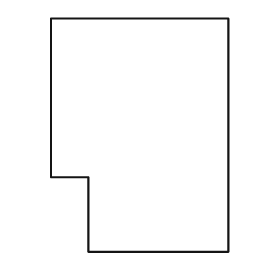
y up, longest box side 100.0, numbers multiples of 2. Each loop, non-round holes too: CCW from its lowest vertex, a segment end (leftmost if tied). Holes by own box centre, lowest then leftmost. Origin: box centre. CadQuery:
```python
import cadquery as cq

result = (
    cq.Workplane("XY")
    .moveTo(-22.0, -50.0)
    .lineTo(38.0, -50.0)
    .lineTo(38.0, 50.0)
    .lineTo(-38.0, 50.0)
    .lineTo(-38.0, -18.0)
    .lineTo(-22.0, -18.0)
    .close()
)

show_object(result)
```